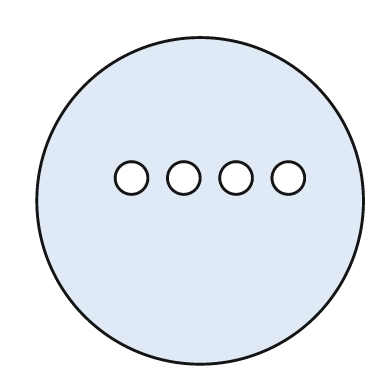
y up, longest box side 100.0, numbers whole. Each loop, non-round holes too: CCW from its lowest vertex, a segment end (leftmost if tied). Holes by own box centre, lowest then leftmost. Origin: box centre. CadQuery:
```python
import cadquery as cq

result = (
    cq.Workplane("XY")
    .moveTo(0.0, 0.0)
    .circle(50.0)
    .moveTo(-21.0, 7.0)
    .circle(5.0)
    .moveTo(-5.0, 7.0)
    .circle(5.0)
    .moveTo(11.0, 7.0)
    .circle(5.0)
    .moveTo(27.0, 7.0)
    .circle(5.0)
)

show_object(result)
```